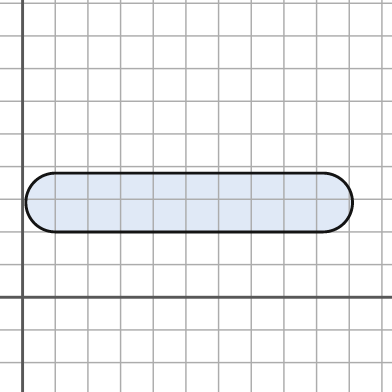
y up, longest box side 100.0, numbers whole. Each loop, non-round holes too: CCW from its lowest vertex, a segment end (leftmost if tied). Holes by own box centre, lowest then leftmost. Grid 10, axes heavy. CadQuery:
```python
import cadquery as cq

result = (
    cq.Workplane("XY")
    .moveTo(10.0, 20.0)
    .lineTo(92.0, 20.0)
    .threePointArc((101.0, 29.0), (92.0, 38.0))
    .lineTo(10.0, 38.0)
    .threePointArc((1.0, 29.0), (10.0, 20.0))
    .close()
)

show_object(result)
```